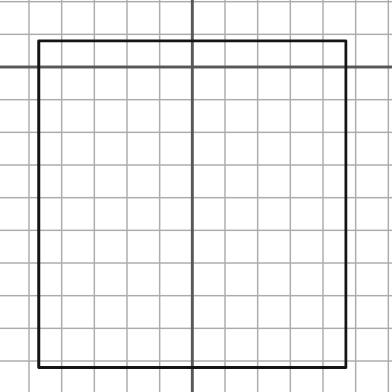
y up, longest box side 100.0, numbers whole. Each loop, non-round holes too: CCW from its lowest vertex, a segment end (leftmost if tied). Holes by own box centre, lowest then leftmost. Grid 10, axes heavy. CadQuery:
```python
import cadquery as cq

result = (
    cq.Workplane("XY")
    .moveTo(-47.0, -92.0)
    .lineTo(47.0, -92.0)
    .lineTo(47.0, 8.0)
    .lineTo(-47.0, 8.0)
    .close()
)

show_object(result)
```